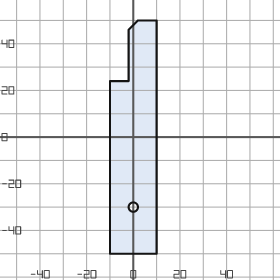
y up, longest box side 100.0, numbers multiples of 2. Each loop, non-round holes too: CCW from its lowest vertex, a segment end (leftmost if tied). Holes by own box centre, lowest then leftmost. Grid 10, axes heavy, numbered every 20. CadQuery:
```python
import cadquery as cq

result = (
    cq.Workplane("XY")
    .moveTo(-10.0, -50.0)
    .lineTo(10.0, -50.0)
    .lineTo(10.0, 50.0)
    .lineTo(2.0, 50.0)
    .lineTo(-2.0, 46.0)
    .lineTo(-2.0, 24.0)
    .lineTo(-10.0, 24.0)
    .close()
    .moveTo(0.0, -30.0)
    .circle(2.0)
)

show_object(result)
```